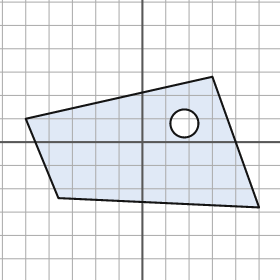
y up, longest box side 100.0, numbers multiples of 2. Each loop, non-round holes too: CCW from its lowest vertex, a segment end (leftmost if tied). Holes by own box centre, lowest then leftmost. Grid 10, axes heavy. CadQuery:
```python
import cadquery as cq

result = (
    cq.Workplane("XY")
    .moveTo(50.0, -28.0)
    .lineTo(30.0, 28.0)
    .lineTo(-50.0, 10.0)
    .lineTo(-36.0, -24.0)
    .close()
    .moveTo(18.0, 8.0)
    .circle(6.0)
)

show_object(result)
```